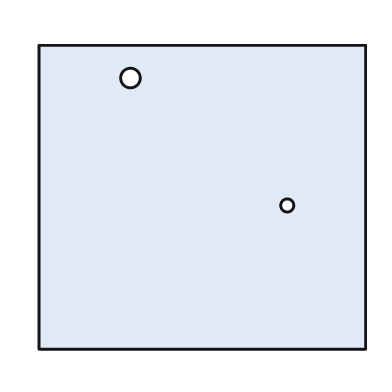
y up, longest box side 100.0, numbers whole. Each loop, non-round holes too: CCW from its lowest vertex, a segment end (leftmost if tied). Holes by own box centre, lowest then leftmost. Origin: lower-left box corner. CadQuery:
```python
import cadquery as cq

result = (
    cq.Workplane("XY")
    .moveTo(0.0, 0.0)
    .lineTo(100.0, 0.0)
    .lineTo(100.0, 93.0)
    .lineTo(0.0, 93.0)
    .close()
    .moveTo(76.0, 44.0)
    .circle(2.0)
    .moveTo(28.0, 83.0)
    .circle(3.0)
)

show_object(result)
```